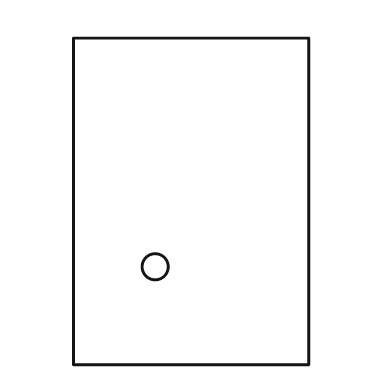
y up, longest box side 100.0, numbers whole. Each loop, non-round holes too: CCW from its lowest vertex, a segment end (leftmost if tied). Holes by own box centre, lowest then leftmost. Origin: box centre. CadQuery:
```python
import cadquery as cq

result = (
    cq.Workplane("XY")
    .moveTo(-36.0, -50.0)
    .lineTo(36.0, -50.0)
    .lineTo(36.0, 50.0)
    .lineTo(-36.0, 50.0)
    .close()
    .moveTo(-11.0, -20.0)
    .circle(4.0)
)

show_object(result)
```